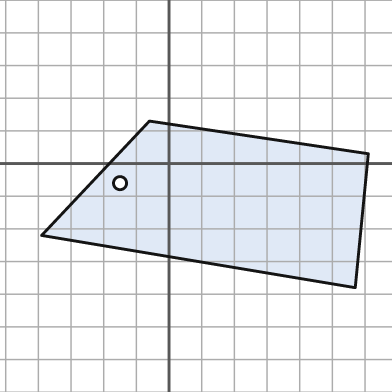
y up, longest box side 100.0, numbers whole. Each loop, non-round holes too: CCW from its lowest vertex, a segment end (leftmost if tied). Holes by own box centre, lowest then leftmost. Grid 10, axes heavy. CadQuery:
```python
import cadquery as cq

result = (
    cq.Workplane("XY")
    .moveTo(57.0, -38.0)
    .lineTo(61.0, 3.0)
    .lineTo(-6.0, 13.0)
    .lineTo(-39.0, -22.0)
    .close()
    .moveTo(-15.0, -6.0)
    .circle(2.0)
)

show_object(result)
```